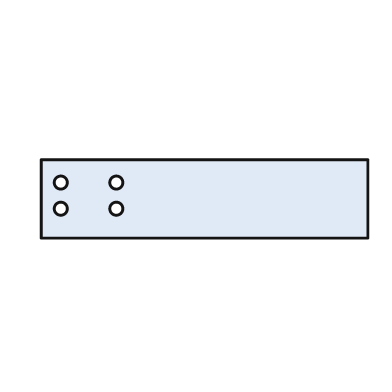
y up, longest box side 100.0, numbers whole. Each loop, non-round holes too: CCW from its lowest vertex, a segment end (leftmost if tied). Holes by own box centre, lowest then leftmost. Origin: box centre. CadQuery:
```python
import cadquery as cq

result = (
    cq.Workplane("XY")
    .moveTo(-50.0, -12.0)
    .lineTo(50.0, -12.0)
    .lineTo(50.0, 12.0)
    .lineTo(-50.0, 12.0)
    .close()
    .moveTo(-44.0, -3.0)
    .circle(2.0)
    .moveTo(-27.0, -3.0)
    .circle(2.0)
    .moveTo(-44.0, 5.0)
    .circle(2.0)
    .moveTo(-27.0, 5.0)
    .circle(2.0)
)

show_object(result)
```